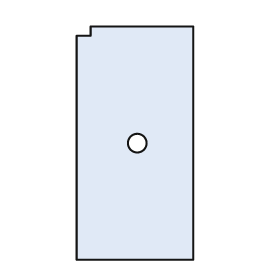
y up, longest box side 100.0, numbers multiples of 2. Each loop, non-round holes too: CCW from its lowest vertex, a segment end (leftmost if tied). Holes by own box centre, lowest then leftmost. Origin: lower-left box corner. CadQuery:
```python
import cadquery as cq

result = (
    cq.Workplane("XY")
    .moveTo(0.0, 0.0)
    .lineTo(50.0, 0.0)
    .lineTo(50.0, 100.0)
    .lineTo(6.0, 100.0)
    .lineTo(6.0, 96.0)
    .lineTo(0.0, 96.0)
    .close()
    .moveTo(26.0, 50.0)
    .circle(4.0)
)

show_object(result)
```